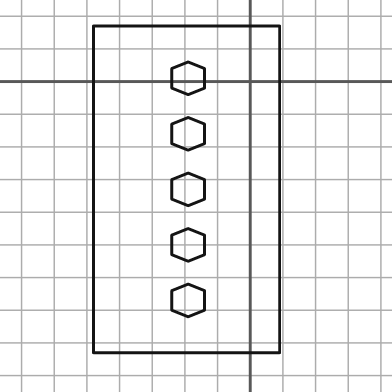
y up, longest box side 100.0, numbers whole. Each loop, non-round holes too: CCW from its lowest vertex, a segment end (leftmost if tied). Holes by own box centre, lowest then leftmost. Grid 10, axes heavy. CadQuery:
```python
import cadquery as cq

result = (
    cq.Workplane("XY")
    .moveTo(-48.0, -83.0)
    .lineTo(9.0, -83.0)
    .lineTo(9.0, 17.0)
    .lineTo(-48.0, 17.0)
    .close()
    .moveTo(-19.0, -72.0)
    .lineTo(-14.0, -70.0)
    .lineTo(-14.0, -64.0)
    .lineTo(-19.0, -62.0)
    .lineTo(-24.0, -64.0)
    .lineTo(-24.0, -70.0)
    .close()
    .moveTo(-19.0, -55.0)
    .lineTo(-14.0, -53.0)
    .lineTo(-14.0, -47.0)
    .lineTo(-19.0, -45.0)
    .lineTo(-24.0, -47.0)
    .lineTo(-24.0, -53.0)
    .close()
    .moveTo(-19.0, -38.0)
    .lineTo(-14.0, -36.0)
    .lineTo(-14.0, -30.0)
    .lineTo(-19.0, -28.0)
    .lineTo(-24.0, -30.0)
    .lineTo(-24.0, -36.0)
    .close()
    .moveTo(-19.0, -21.0)
    .lineTo(-14.0, -19.0)
    .lineTo(-14.0, -13.0)
    .lineTo(-19.0, -11.0)
    .lineTo(-24.0, -13.0)
    .lineTo(-24.0, -19.0)
    .close()
    .moveTo(-19.0, -4.0)
    .lineTo(-14.0, -2.0)
    .lineTo(-14.0, 4.0)
    .lineTo(-19.0, 6.0)
    .lineTo(-24.0, 4.0)
    .lineTo(-24.0, -2.0)
    .close()
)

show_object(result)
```